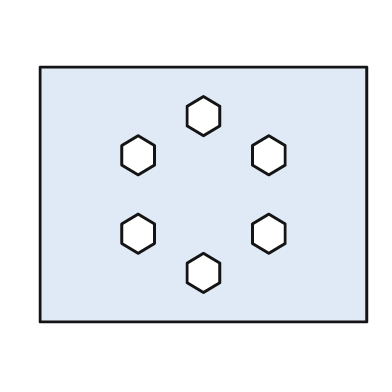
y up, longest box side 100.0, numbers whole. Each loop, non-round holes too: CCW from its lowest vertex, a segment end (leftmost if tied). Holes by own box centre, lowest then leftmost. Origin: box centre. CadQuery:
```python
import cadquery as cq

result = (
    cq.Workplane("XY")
    .moveTo(-50.0, -39.0)
    .lineTo(50.0, -39.0)
    .lineTo(50.0, 39.0)
    .lineTo(-50.0, 39.0)
    .close()
    .moveTo(0.0, -30.0)
    .lineTo(5.0, -27.0)
    .lineTo(5.0, -21.0)
    .lineTo(0.0, -18.0)
    .lineTo(-5.0, -21.0)
    .lineTo(-5.0, -27.0)
    .close()
    .moveTo(-20.0, -18.0)
    .lineTo(-15.0, -15.0)
    .lineTo(-15.0, -9.0)
    .lineTo(-20.0, -6.0)
    .lineTo(-25.0, -9.0)
    .lineTo(-25.0, -15.0)
    .close()
    .moveTo(20.0, -18.0)
    .lineTo(25.0, -15.0)
    .lineTo(25.0, -9.0)
    .lineTo(20.0, -6.0)
    .lineTo(15.0, -9.0)
    .lineTo(15.0, -15.0)
    .close()
    .moveTo(-20.0, 6.0)
    .lineTo(-15.0, 9.0)
    .lineTo(-15.0, 15.0)
    .lineTo(-20.0, 18.0)
    .lineTo(-25.0, 15.0)
    .lineTo(-25.0, 9.0)
    .close()
    .moveTo(20.0, 6.0)
    .lineTo(25.0, 9.0)
    .lineTo(25.0, 15.0)
    .lineTo(20.0, 18.0)
    .lineTo(15.0, 15.0)
    .lineTo(15.0, 9.0)
    .close()
    .moveTo(0.0, 18.0)
    .lineTo(5.0, 21.0)
    .lineTo(5.0, 27.0)
    .lineTo(0.0, 30.0)
    .lineTo(-5.0, 27.0)
    .lineTo(-5.0, 21.0)
    .close()
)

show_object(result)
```